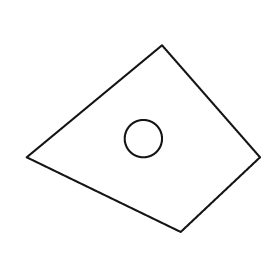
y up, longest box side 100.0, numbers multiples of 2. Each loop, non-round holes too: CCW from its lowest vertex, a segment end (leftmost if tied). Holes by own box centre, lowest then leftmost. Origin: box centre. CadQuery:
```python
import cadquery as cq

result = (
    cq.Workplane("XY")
    .moveTo(16.0, -40.0)
    .lineTo(50.0, -8.0)
    .lineTo(8.0, 40.0)
    .lineTo(-50.0, -8.0)
    .close()
    .moveTo(0.0, 0.0)
    .circle(8.0)
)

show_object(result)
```